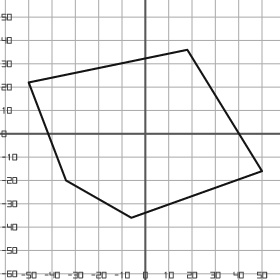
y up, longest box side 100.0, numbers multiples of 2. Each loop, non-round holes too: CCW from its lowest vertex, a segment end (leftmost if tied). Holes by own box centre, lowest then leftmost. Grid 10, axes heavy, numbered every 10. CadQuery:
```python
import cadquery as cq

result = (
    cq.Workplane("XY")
    .moveTo(-6.0, -36.0)
    .lineTo(50.0, -16.0)
    .lineTo(18.0, 36.0)
    .lineTo(-50.0, 22.0)
    .lineTo(-34.0, -20.0)
    .close()
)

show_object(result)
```